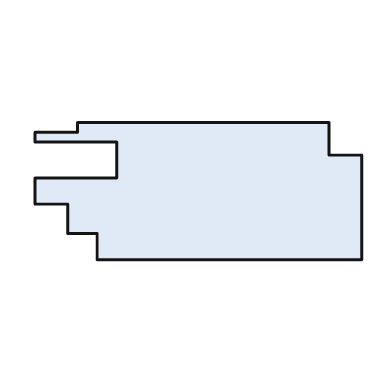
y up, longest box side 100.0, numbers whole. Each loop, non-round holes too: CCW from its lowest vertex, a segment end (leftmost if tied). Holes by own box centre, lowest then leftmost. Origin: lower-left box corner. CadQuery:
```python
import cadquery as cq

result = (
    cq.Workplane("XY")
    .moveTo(19.0, 0.0)
    .lineTo(100.0, 0.0)
    .lineTo(100.0, 32.0)
    .lineTo(90.0, 32.0)
    .lineTo(90.0, 42.0)
    .lineTo(13.0, 42.0)
    .lineTo(13.0, 39.0)
    .lineTo(0.0, 39.0)
    .lineTo(0.0, 36.0)
    .lineTo(25.0, 36.0)
    .lineTo(25.0, 25.0)
    .lineTo(0.0, 25.0)
    .lineTo(0.0, 17.0)
    .lineTo(10.0, 17.0)
    .lineTo(10.0, 8.0)
    .lineTo(19.0, 8.0)
    .close()
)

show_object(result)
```